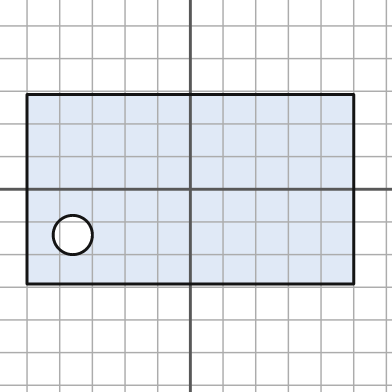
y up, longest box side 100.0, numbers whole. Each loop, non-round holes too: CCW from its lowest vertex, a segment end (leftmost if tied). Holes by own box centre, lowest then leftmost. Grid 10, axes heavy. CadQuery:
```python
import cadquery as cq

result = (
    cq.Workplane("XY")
    .moveTo(-50.0, -29.0)
    .lineTo(50.0, -29.0)
    .lineTo(50.0, 29.0)
    .lineTo(-50.0, 29.0)
    .close()
    .moveTo(-36.0, -14.0)
    .circle(6.0)
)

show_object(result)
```